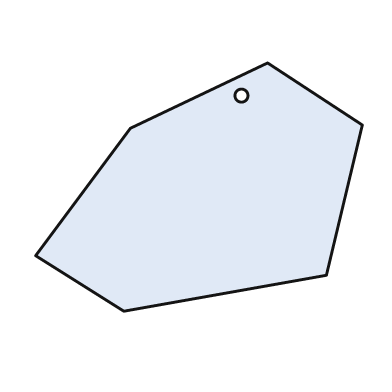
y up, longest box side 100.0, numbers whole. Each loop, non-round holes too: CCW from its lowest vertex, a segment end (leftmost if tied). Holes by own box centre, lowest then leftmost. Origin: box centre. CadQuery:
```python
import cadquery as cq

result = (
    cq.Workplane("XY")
    .moveTo(-23.0, -38.0)
    .lineTo(39.0, -27.0)
    .lineTo(50.0, 19.0)
    .lineTo(21.0, 38.0)
    .lineTo(-21.0, 18.0)
    .lineTo(-50.0, -21.0)
    .close()
    .moveTo(13.0, 28.0)
    .circle(2.0)
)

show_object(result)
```